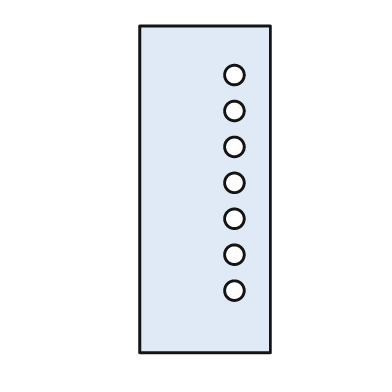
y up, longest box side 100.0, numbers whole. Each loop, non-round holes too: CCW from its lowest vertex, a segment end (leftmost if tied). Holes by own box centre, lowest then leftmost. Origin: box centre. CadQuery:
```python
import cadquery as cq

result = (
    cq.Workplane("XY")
    .moveTo(-20.0, -50.0)
    .lineTo(20.0, -50.0)
    .lineTo(20.0, 50.0)
    .lineTo(-20.0, 50.0)
    .close()
    .moveTo(9.0, -31.0)
    .circle(3.0)
    .moveTo(9.0, -20.0)
    .circle(3.0)
    .moveTo(9.0, -9.0)
    .circle(3.0)
    .moveTo(9.0, 2.0)
    .circle(3.0)
    .moveTo(9.0, 13.0)
    .circle(3.0)
    .moveTo(9.0, 24.0)
    .circle(3.0)
    .moveTo(9.0, 35.0)
    .circle(3.0)
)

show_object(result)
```